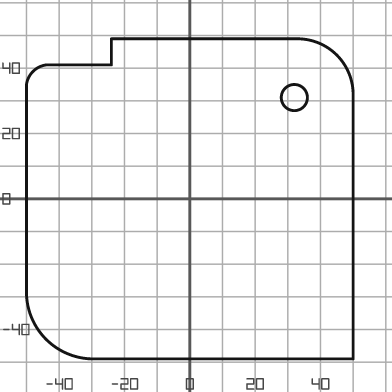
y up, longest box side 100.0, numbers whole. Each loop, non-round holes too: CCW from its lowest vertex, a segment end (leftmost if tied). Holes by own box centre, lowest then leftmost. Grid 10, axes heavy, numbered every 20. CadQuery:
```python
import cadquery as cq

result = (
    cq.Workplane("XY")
    .moveTo(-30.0, -49.0)
    .lineTo(50.0, -49.0)
    .lineTo(50.0, 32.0)
    .threePointArc((45.0, 44.0), (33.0, 49.0))
    .lineTo(-24.0, 49.0)
    .lineTo(-24.0, 41.0)
    .lineTo(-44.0, 41.0)
    .threePointArc((-48.0, 39.0), (-50.0, 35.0))
    .lineTo(-50.0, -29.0)
    .threePointArc((-44.0, -43.0), (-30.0, -49.0))
    .close()
    .moveTo(32.0, 31.0)
    .circle(4.0)
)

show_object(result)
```